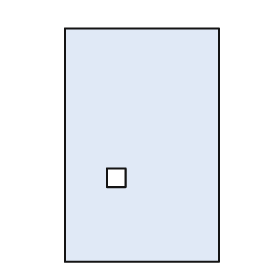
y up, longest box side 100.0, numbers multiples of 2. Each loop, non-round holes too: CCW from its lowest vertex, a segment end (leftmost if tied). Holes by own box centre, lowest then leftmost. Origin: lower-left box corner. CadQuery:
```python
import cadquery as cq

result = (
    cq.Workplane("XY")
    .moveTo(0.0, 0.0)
    .lineTo(66.0, 0.0)
    .lineTo(66.0, 100.0)
    .lineTo(0.0, 100.0)
    .close()
    .moveTo(18.0, 32.0)
    .lineTo(26.0, 32.0)
    .lineTo(26.0, 40.0)
    .lineTo(18.0, 40.0)
    .close()
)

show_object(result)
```